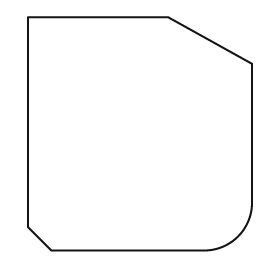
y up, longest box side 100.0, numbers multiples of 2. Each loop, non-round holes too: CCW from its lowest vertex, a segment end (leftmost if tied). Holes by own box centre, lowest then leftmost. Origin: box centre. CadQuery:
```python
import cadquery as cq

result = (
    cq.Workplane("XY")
    .moveTo(-38.0, -50.0)
    .lineTo(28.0, -50.0)
    .threePointArc((42.0, -44.0), (48.0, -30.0))
    .lineTo(48.0, 30.0)
    .lineTo(12.0, 50.0)
    .lineTo(-48.0, 50.0)
    .lineTo(-48.0, -40.0)
    .close()
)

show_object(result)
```